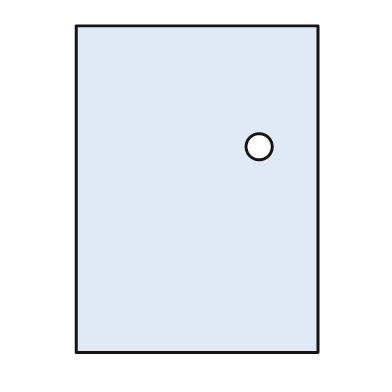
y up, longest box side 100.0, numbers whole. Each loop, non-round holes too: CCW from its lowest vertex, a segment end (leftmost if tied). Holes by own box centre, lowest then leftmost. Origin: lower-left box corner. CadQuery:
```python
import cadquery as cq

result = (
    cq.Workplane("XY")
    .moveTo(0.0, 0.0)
    .lineTo(74.0, 0.0)
    .lineTo(74.0, 100.0)
    .lineTo(0.0, 100.0)
    .close()
    .moveTo(56.0, 63.0)
    .circle(4.0)
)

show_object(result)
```